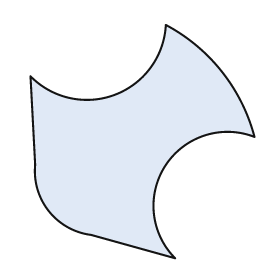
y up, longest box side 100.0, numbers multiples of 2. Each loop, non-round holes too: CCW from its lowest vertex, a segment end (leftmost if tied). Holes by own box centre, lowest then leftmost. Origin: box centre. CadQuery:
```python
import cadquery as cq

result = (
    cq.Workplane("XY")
    .moveTo(14.0, -50.0)
    .threePointArc((10.0, -10.0), (48.0, 2.0))
    .threePointArc((34.0, 30.0), (10.0, 50.0))
    .threePointArc((-12.0, 20.0), (-48.0, 28.0))
    .lineTo(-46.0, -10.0)
    .threePointArc((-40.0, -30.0), (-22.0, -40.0))
    .close()
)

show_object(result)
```